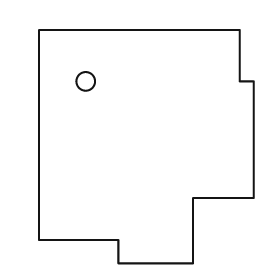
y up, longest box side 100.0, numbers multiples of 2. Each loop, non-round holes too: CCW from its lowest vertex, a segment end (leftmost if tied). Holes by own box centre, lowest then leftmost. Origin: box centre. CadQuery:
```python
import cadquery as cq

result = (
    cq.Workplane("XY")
    .moveTo(-12.0, -50.0)
    .lineTo(20.0, -50.0)
    .lineTo(20.0, -22.0)
    .lineTo(46.0, -22.0)
    .lineTo(46.0, 28.0)
    .lineTo(40.0, 28.0)
    .lineTo(40.0, 50.0)
    .lineTo(-46.0, 50.0)
    .lineTo(-46.0, -40.0)
    .lineTo(-12.0, -40.0)
    .close()
    .moveTo(-26.0, 28.0)
    .circle(4.0)
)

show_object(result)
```